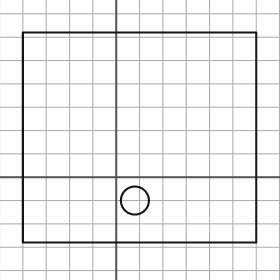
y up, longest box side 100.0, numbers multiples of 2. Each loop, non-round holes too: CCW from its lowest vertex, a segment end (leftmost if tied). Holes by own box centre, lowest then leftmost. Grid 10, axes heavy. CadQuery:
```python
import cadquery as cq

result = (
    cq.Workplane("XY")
    .moveTo(-40.0, -28.0)
    .lineTo(60.0, -28.0)
    .lineTo(60.0, 62.0)
    .lineTo(-40.0, 62.0)
    .close()
    .moveTo(8.0, -10.0)
    .circle(6.0)
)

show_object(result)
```